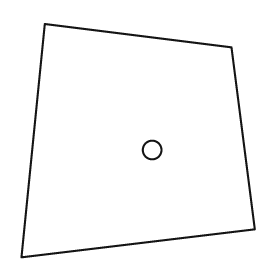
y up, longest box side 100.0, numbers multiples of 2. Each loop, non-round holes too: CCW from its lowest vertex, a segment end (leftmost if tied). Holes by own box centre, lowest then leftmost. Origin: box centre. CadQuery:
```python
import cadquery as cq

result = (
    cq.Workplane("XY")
    .moveTo(-50.0, -50.0)
    .lineTo(50.0, -38.0)
    .lineTo(40.0, 40.0)
    .lineTo(-40.0, 50.0)
    .close()
    .moveTo(6.0, -4.0)
    .circle(4.0)
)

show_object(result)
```